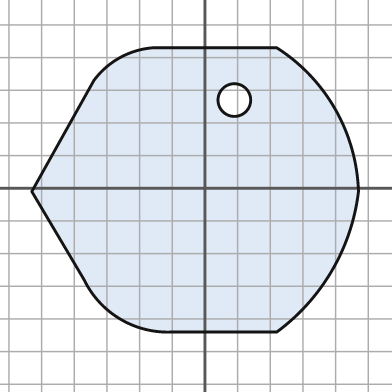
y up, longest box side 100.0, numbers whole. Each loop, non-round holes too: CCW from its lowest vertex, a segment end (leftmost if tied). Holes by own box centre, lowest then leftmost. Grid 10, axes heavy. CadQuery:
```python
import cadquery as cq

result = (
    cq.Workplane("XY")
    .moveTo(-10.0, -44.0)
    .lineTo(22.0, -44.0)
    .threePointArc((39.0, -25.0), (47.0, -1.0))
    .threePointArc((40.0, 24.0), (22.0, 43.0))
    .lineTo(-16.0, 43.0)
    .threePointArc((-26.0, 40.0), (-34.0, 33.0))
    .lineTo(-53.0, -1.0)
    .lineTo(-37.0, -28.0)
    .threePointArc((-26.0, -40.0), (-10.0, -44.0))
    .close()
    .moveTo(9.0, 27.0)
    .circle(5.0)
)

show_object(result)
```